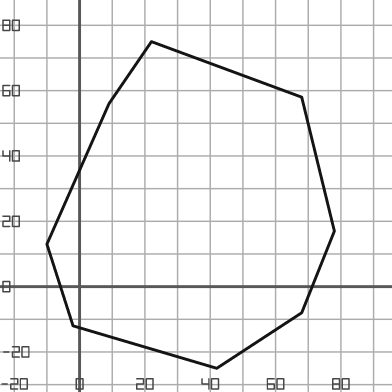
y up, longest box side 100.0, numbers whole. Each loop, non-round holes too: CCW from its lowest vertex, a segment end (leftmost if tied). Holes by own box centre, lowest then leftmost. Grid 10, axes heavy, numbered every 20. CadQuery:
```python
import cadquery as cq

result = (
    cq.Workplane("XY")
    .moveTo(42.0, -25.0)
    .lineTo(68.0, -8.0)
    .lineTo(78.0, 17.0)
    .lineTo(68.0, 58.0)
    .lineTo(22.0, 75.0)
    .lineTo(9.0, 56.0)
    .lineTo(-10.0, 13.0)
    .lineTo(-2.0, -12.0)
    .close()
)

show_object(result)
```